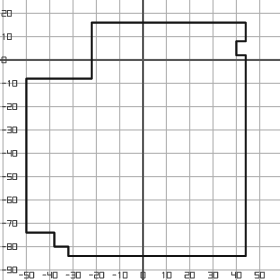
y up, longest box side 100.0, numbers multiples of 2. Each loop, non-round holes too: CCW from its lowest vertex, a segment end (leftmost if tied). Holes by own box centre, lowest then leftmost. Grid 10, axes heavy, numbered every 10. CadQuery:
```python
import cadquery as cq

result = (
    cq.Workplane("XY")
    .moveTo(-32.0, -84.0)
    .lineTo(44.0, -84.0)
    .lineTo(44.0, 2.0)
    .lineTo(40.0, 2.0)
    .lineTo(40.0, 8.0)
    .lineTo(44.0, 8.0)
    .lineTo(44.0, 16.0)
    .lineTo(-22.0, 16.0)
    .lineTo(-22.0, -8.0)
    .lineTo(-50.0, -8.0)
    .lineTo(-50.0, -74.0)
    .lineTo(-38.0, -74.0)
    .lineTo(-38.0, -80.0)
    .lineTo(-32.0, -80.0)
    .close()
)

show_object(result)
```